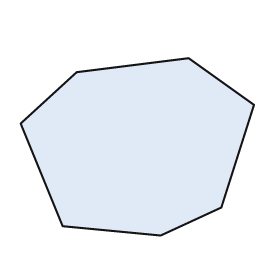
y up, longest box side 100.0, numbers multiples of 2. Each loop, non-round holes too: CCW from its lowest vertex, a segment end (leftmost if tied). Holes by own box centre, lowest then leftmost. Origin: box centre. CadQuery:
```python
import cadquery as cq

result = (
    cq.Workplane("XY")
    .moveTo(10.0, -38.0)
    .lineTo(36.0, -26.0)
    .lineTo(50.0, 18.0)
    .lineTo(22.0, 38.0)
    .lineTo(-26.0, 32.0)
    .lineTo(-50.0, 10.0)
    .lineTo(-32.0, -34.0)
    .close()
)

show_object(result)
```